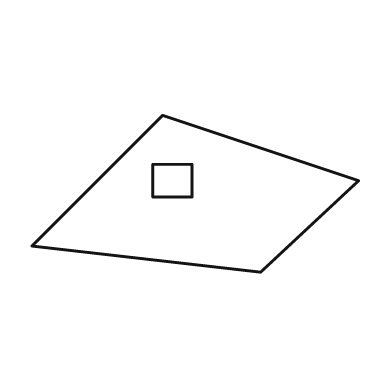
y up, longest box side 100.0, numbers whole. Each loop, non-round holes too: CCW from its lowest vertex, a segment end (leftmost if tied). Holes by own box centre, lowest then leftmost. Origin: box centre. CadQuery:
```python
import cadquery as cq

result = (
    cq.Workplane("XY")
    .moveTo(20.0, -24.0)
    .lineTo(50.0, 4.0)
    .lineTo(-10.0, 24.0)
    .lineTo(-50.0, -16.0)
    .close()
    .moveTo(-13.0, -1.0)
    .lineTo(-1.0, -1.0)
    .lineTo(-1.0, 9.0)
    .lineTo(-13.0, 9.0)
    .close()
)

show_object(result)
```